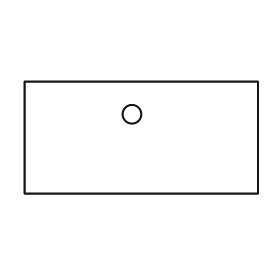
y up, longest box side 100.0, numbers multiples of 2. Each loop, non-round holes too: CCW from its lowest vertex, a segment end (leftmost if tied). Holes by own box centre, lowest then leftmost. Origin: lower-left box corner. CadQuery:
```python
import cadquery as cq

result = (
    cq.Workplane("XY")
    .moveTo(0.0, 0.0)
    .lineTo(100.0, 0.0)
    .lineTo(100.0, 48.0)
    .lineTo(0.0, 48.0)
    .close()
    .moveTo(46.0, 34.0)
    .circle(4.0)
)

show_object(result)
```